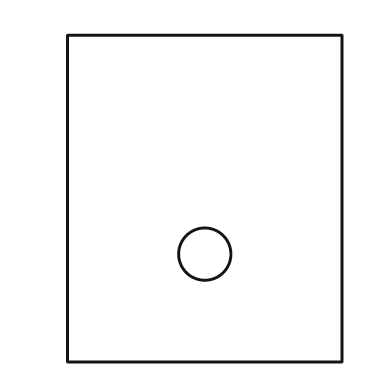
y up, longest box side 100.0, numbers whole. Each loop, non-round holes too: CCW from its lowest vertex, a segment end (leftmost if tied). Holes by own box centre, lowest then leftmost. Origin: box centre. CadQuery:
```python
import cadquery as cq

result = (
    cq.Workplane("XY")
    .moveTo(-42.0, -50.0)
    .lineTo(42.0, -50.0)
    .lineTo(42.0, 50.0)
    .lineTo(-42.0, 50.0)
    .close()
    .moveTo(0.0, -17.0)
    .circle(8.0)
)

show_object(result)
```